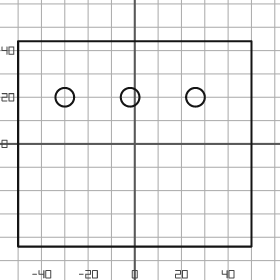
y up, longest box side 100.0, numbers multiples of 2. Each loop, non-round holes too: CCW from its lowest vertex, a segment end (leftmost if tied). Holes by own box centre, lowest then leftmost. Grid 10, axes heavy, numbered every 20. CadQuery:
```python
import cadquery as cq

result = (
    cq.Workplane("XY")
    .moveTo(-50.0, -44.0)
    .lineTo(50.0, -44.0)
    .lineTo(50.0, 44.0)
    .lineTo(-50.0, 44.0)
    .close()
    .moveTo(-30.0, 20.0)
    .circle(4.0)
    .moveTo(-2.0, 20.0)
    .circle(4.0)
    .moveTo(26.0, 20.0)
    .circle(4.0)
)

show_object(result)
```